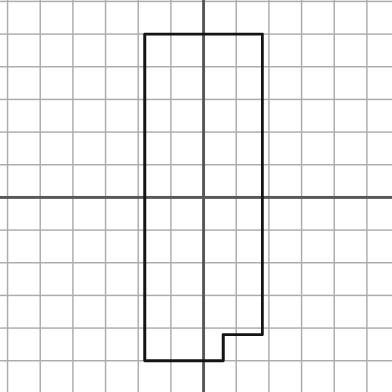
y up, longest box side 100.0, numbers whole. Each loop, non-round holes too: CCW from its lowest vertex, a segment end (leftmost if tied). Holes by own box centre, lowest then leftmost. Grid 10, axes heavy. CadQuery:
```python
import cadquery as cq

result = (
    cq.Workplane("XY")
    .moveTo(-18.0, -50.0)
    .lineTo(6.0, -50.0)
    .lineTo(6.0, -42.0)
    .lineTo(18.0, -42.0)
    .lineTo(18.0, 50.0)
    .lineTo(-18.0, 50.0)
    .close()
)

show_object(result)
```